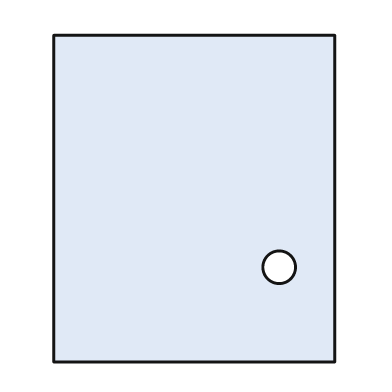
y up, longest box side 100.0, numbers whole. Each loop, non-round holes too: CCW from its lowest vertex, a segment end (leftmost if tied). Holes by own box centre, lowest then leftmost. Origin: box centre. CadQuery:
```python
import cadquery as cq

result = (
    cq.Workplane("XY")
    .moveTo(-43.0, -50.0)
    .lineTo(43.0, -50.0)
    .lineTo(43.0, 50.0)
    .lineTo(-43.0, 50.0)
    .close()
    .moveTo(26.0, -21.0)
    .circle(5.0)
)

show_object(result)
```